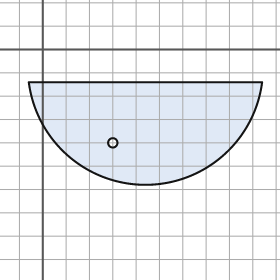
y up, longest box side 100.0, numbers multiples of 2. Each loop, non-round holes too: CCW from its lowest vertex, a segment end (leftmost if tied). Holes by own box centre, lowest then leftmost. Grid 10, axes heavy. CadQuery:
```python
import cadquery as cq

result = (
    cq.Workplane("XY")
    .moveTo(-6.0, -14.0)
    .threePointArc((44.0, -58.0), (94.0, -14.0))
    .close()
    .moveTo(30.0, -40.0)
    .circle(2.0)
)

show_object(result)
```